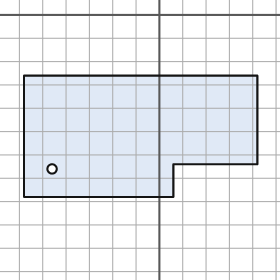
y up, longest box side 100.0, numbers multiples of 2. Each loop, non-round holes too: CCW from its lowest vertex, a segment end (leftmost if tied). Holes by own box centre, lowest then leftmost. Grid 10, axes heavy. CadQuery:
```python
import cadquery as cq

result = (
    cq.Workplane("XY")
    .moveTo(-58.0, -78.0)
    .lineTo(6.0, -78.0)
    .lineTo(6.0, -64.0)
    .lineTo(42.0, -64.0)
    .lineTo(42.0, -26.0)
    .lineTo(-58.0, -26.0)
    .close()
    .moveTo(-46.0, -66.0)
    .circle(2.0)
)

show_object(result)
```